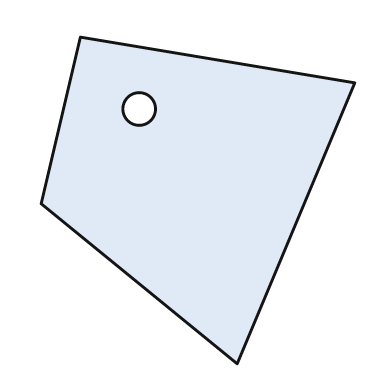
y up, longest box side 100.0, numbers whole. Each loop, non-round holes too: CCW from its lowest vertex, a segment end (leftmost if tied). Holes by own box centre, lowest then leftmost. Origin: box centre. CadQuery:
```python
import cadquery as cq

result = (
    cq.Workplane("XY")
    .moveTo(12.0, -50.0)
    .lineTo(48.0, 36.0)
    .lineTo(-36.0, 50.0)
    .lineTo(-48.0, -1.0)
    .close()
    .moveTo(-18.0, 28.0)
    .circle(5.0)
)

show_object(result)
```